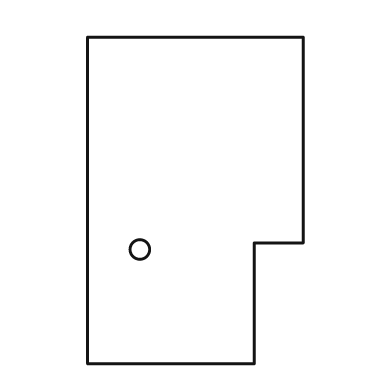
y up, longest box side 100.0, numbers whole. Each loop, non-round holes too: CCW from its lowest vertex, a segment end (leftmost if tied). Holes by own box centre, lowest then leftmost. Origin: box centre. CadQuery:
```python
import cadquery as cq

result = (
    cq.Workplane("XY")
    .moveTo(-33.0, -50.0)
    .lineTo(18.0, -50.0)
    .lineTo(18.0, -13.0)
    .lineTo(33.0, -13.0)
    .lineTo(33.0, 50.0)
    .lineTo(-33.0, 50.0)
    .close()
    .moveTo(-17.0, -15.0)
    .circle(3.0)
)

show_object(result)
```